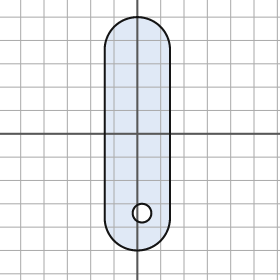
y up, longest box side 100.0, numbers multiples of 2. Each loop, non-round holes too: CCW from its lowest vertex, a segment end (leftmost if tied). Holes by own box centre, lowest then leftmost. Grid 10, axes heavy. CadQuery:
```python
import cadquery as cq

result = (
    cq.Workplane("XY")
    .moveTo(-14.0, -36.0)
    .threePointArc((0.0, -50.0), (14.0, -36.0))
    .lineTo(14.0, 36.0)
    .threePointArc((0.0, 50.0), (-14.0, 36.0))
    .close()
    .moveTo(2.0, -34.0)
    .circle(4.0)
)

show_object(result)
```